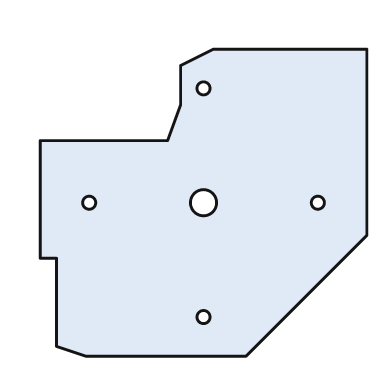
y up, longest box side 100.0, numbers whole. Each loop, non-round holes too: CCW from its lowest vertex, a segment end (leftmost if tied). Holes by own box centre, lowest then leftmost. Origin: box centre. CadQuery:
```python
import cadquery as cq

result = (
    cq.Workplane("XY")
    .moveTo(-36.0, -47.0)
    .lineTo(13.0, -47.0)
    .lineTo(50.0, -10.0)
    .lineTo(50.0, 47.0)
    .lineTo(3.0, 47.0)
    .lineTo(-7.0, 42.0)
    .lineTo(-7.0, 30.0)
    .lineTo(-11.0, 19.0)
    .lineTo(-50.0, 19.0)
    .lineTo(-50.0, -17.0)
    .lineTo(-45.0, -17.0)
    .lineTo(-45.0, -44.0)
    .close()
    .moveTo(0.0, -35.0)
    .circle(2.0)
    .moveTo(-35.0, 0.0)
    .circle(2.0)
    .moveTo(0.0, 0.0)
    .circle(4.0)
    .moveTo(35.0, 0.0)
    .circle(2.0)
    .moveTo(0.0, 35.0)
    .circle(2.0)
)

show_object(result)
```